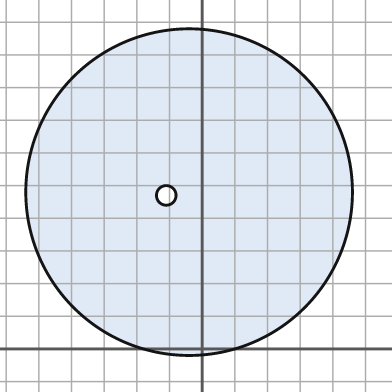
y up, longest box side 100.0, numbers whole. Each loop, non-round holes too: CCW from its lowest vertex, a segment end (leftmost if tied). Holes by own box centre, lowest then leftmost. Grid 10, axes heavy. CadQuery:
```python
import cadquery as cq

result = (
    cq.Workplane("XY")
    .moveTo(-4.0, 48.0)
    .circle(50.0)
    .moveTo(-11.0, 47.0)
    .circle(3.0)
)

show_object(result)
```